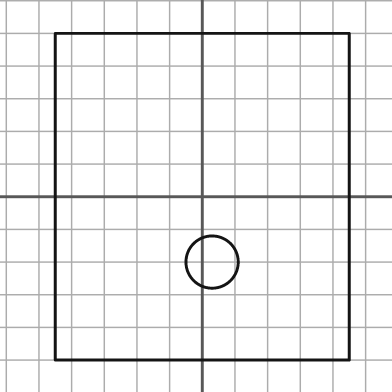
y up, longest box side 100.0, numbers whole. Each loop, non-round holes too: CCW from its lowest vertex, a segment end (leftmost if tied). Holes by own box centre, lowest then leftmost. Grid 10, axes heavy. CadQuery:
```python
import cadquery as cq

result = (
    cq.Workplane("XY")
    .moveTo(-45.0, -50.0)
    .lineTo(45.0, -50.0)
    .lineTo(45.0, 50.0)
    .lineTo(-45.0, 50.0)
    .close()
    .moveTo(3.0, -20.0)
    .circle(8.0)
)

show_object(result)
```